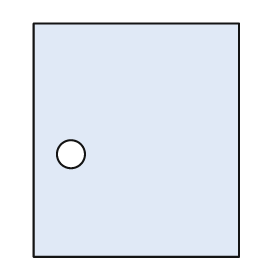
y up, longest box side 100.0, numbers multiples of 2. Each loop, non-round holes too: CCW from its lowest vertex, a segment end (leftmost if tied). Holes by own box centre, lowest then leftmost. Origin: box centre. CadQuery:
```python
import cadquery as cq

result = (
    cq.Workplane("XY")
    .moveTo(-44.0, -50.0)
    .lineTo(44.0, -50.0)
    .lineTo(44.0, 50.0)
    .lineTo(-44.0, 50.0)
    .close()
    .moveTo(-28.0, -6.0)
    .circle(6.0)
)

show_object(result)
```